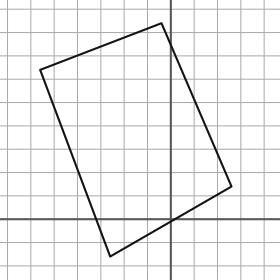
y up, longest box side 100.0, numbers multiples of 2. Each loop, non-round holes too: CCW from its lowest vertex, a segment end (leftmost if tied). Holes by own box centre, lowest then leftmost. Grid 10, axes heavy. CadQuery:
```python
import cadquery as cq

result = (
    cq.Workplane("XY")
    .moveTo(-26.0, -16.0)
    .lineTo(26.0, 14.0)
    .lineTo(-4.0, 84.0)
    .lineTo(-56.0, 64.0)
    .close()
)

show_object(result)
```